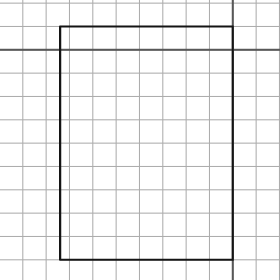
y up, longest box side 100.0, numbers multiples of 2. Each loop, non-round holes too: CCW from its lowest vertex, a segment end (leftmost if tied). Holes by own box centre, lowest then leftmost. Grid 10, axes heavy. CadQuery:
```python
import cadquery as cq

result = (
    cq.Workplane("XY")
    .moveTo(-74.0, -90.0)
    .lineTo(0.0, -90.0)
    .lineTo(0.0, 10.0)
    .lineTo(-74.0, 10.0)
    .close()
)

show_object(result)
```